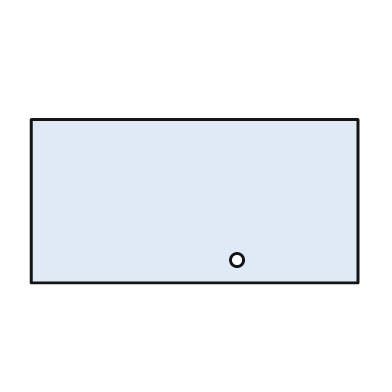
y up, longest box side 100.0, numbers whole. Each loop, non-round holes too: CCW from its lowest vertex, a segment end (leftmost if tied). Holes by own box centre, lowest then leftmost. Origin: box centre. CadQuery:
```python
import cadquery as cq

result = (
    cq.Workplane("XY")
    .moveTo(-50.0, -25.0)
    .lineTo(50.0, -25.0)
    .lineTo(50.0, 25.0)
    .lineTo(-50.0, 25.0)
    .close()
    .moveTo(13.0, -18.0)
    .circle(2.0)
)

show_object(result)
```